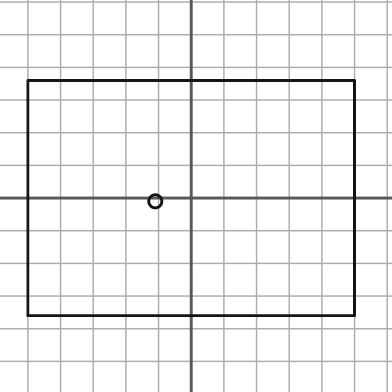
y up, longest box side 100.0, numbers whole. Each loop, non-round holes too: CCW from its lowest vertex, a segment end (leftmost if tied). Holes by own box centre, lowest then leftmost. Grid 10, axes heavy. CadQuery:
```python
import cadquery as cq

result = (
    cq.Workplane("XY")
    .moveTo(-50.0, -36.0)
    .lineTo(50.0, -36.0)
    .lineTo(50.0, 36.0)
    .lineTo(-50.0, 36.0)
    .close()
    .moveTo(-11.0, -1.0)
    .circle(2.0)
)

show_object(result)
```